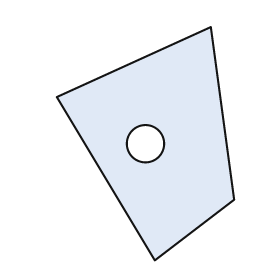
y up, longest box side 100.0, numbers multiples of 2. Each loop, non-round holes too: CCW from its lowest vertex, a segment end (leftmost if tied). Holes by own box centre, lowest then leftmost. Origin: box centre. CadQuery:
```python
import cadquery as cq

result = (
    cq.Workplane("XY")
    .moveTo(4.0, -50.0)
    .lineTo(38.0, -24.0)
    .lineTo(28.0, 50.0)
    .lineTo(-38.0, 20.0)
    .close()
    .moveTo(0.0, 0.0)
    .circle(8.0)
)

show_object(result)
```